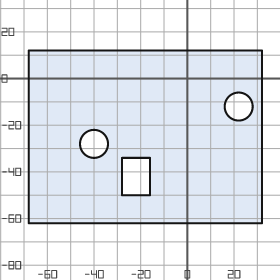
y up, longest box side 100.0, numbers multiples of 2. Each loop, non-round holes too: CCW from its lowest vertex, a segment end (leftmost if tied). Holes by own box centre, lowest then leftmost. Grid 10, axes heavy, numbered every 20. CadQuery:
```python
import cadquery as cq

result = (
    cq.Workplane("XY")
    .moveTo(-68.0, -62.0)
    .lineTo(32.0, -62.0)
    .lineTo(32.0, 12.0)
    .lineTo(-68.0, 12.0)
    .close()
    .moveTo(-28.0, -50.0)
    .lineTo(-16.0, -50.0)
    .lineTo(-16.0, -34.0)
    .lineTo(-28.0, -34.0)
    .close()
    .moveTo(-40.0, -28.0)
    .circle(6.0)
    .moveTo(22.0, -12.0)
    .circle(6.0)
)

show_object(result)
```